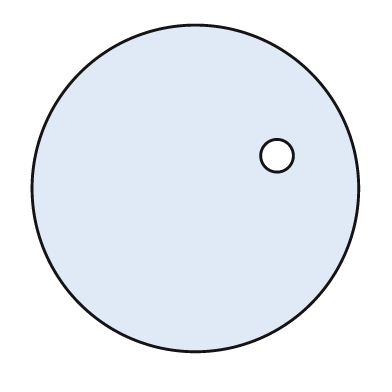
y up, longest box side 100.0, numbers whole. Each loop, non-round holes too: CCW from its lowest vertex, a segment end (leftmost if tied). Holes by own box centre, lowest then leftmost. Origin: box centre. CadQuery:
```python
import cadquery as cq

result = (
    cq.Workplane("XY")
    .moveTo(0.0, 0.0)
    .circle(50.0)
    .moveTo(25.0, 10.0)
    .circle(5.0)
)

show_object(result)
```